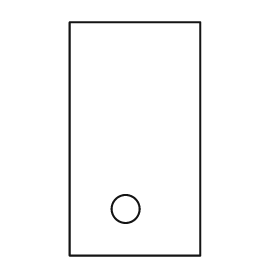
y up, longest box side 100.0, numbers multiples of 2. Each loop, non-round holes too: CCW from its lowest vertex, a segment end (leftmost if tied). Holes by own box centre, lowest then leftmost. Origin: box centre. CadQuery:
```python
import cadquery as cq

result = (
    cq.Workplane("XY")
    .moveTo(-28.0, -50.0)
    .lineTo(28.0, -50.0)
    .lineTo(28.0, 50.0)
    .lineTo(-28.0, 50.0)
    .close()
    .moveTo(-4.0, -30.0)
    .circle(6.0)
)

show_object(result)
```